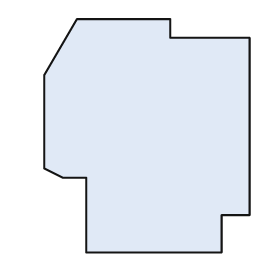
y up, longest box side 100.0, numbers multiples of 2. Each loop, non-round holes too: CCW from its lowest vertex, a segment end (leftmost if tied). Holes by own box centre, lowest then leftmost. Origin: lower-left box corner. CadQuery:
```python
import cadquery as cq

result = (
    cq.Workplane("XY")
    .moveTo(18.0, 0.0)
    .lineTo(76.0, 0.0)
    .lineTo(76.0, 16.0)
    .lineTo(88.0, 16.0)
    .lineTo(88.0, 92.0)
    .lineTo(54.0, 92.0)
    .lineTo(54.0, 100.0)
    .lineTo(14.0, 100.0)
    .lineTo(0.0, 76.0)
    .lineTo(0.0, 36.0)
    .lineTo(8.0, 32.0)
    .lineTo(18.0, 32.0)
    .close()
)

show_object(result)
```